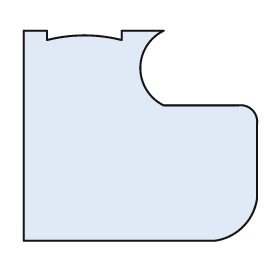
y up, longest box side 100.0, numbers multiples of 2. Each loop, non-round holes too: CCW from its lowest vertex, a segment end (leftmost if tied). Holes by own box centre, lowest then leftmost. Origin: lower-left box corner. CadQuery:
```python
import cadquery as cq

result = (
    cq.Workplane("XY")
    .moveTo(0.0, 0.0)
    .lineTo(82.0, 0.0)
    .threePointArc((94.0, 6.0), (100.0, 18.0))
    .lineTo(100.0, 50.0)
    .threePointArc((98.0, 56.0), (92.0, 58.0))
    .lineTo(60.0, 58.0)
    .threePointArc((50.0, 74.0), (60.0, 90.0))
    .lineTo(42.0, 90.0)
    .lineTo(42.0, 86.0)
    .threePointArc((26.0, 88.0), (10.0, 86.0))
    .lineTo(10.0, 90.0)
    .lineTo(0.0, 90.0)
    .close()
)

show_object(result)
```